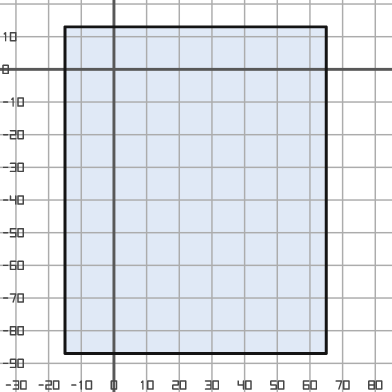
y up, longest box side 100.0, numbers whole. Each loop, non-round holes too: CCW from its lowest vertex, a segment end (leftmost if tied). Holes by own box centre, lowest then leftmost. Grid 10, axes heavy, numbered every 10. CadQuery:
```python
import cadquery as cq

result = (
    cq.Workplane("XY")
    .moveTo(-15.0, -87.0)
    .lineTo(65.0, -87.0)
    .lineTo(65.0, 13.0)
    .lineTo(-15.0, 13.0)
    .close()
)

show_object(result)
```